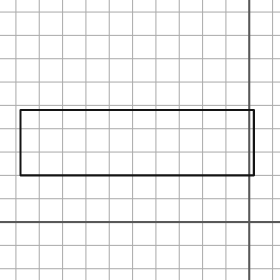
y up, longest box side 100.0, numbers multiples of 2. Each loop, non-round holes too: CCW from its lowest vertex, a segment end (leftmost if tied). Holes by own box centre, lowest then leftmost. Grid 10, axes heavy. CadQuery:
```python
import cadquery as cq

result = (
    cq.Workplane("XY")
    .moveTo(-98.0, 20.0)
    .lineTo(2.0, 20.0)
    .lineTo(2.0, 48.0)
    .lineTo(-98.0, 48.0)
    .close()
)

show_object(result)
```